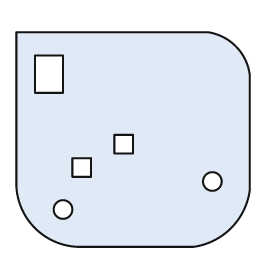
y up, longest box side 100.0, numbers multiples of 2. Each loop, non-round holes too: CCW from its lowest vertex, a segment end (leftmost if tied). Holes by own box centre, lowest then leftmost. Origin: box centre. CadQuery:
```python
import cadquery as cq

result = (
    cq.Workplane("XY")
    .moveTo(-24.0, -46.0)
    .lineTo(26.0, -46.0)
    .threePointArc((42.0, -38.0), (50.0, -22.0))
    .lineTo(50.0, 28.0)
    .threePointArc((44.0, 40.0), (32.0, 46.0))
    .lineTo(-50.0, 46.0)
    .lineTo(-50.0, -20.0)
    .threePointArc((-42.0, -38.0), (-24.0, -46.0))
    .close()
    .moveTo(-30.0, -30.0)
    .circle(4.0)
    .moveTo(34.0, -18.0)
    .circle(4.0)
    .moveTo(-26.0, -16.0)
    .lineTo(-18.0, -16.0)
    .lineTo(-18.0, -8.0)
    .lineTo(-26.0, -8.0)
    .close()
    .moveTo(-8.0, -6.0)
    .lineTo(0.0, -6.0)
    .lineTo(0.0, 2.0)
    .lineTo(-8.0, 2.0)
    .close()
    .moveTo(-42.0, 20.0)
    .lineTo(-30.0, 20.0)
    .lineTo(-30.0, 36.0)
    .lineTo(-42.0, 36.0)
    .close()
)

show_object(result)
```